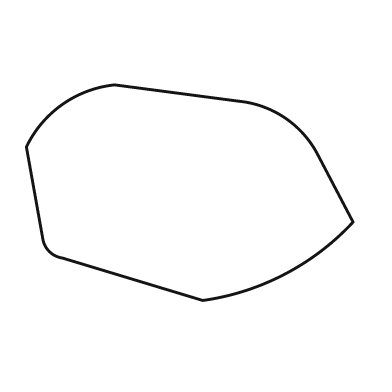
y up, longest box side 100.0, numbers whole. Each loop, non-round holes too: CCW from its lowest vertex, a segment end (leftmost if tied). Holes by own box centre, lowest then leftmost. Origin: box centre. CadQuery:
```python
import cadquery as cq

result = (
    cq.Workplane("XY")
    .moveTo(4.0, -33.0)
    .threePointArc((29.0, -25.0), (50.0, -9.0))
    .lineTo(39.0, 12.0)
    .threePointArc((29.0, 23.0), (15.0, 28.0))
    .lineTo(-23.0, 33.0)
    .threePointArc((-39.0, 27.0), (-50.0, 14.0))
    .lineTo(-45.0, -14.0)
    .threePointArc((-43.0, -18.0), (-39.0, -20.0))
    .close()
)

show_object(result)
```